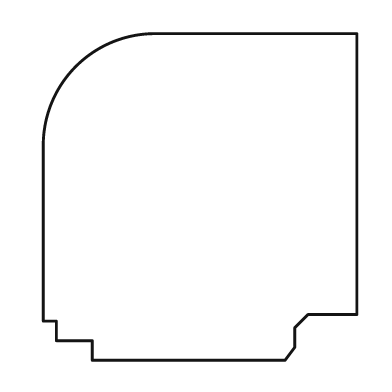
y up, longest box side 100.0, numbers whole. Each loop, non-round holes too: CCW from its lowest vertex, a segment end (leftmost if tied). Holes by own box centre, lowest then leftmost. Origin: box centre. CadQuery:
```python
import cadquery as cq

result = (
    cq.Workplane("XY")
    .moveTo(-33.0, -50.0)
    .lineTo(26.0, -50.0)
    .lineTo(29.0, -46.0)
    .lineTo(29.0, -40.0)
    .lineTo(33.0, -36.0)
    .lineTo(48.0, -36.0)
    .lineTo(48.0, 50.0)
    .lineTo(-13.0, 50.0)
    .threePointArc((-38.0, 40.0), (-48.0, 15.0))
    .lineTo(-48.0, -38.0)
    .lineTo(-44.0, -38.0)
    .lineTo(-44.0, -44.0)
    .lineTo(-33.0, -44.0)
    .close()
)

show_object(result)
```